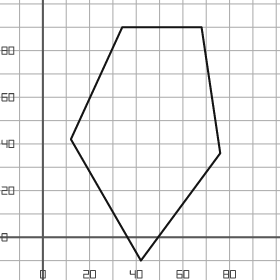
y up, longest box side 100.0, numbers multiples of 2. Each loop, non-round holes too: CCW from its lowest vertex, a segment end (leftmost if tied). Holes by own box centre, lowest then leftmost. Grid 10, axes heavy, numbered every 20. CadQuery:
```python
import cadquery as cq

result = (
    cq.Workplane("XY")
    .moveTo(42.0, -10.0)
    .lineTo(76.0, 36.0)
    .lineTo(68.0, 90.0)
    .lineTo(34.0, 90.0)
    .lineTo(12.0, 42.0)
    .close()
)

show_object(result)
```